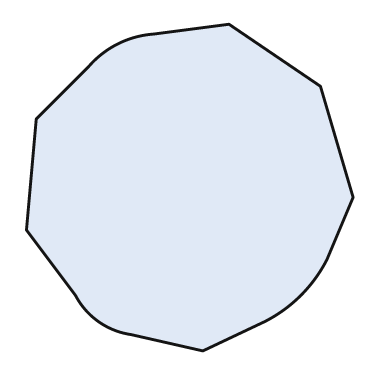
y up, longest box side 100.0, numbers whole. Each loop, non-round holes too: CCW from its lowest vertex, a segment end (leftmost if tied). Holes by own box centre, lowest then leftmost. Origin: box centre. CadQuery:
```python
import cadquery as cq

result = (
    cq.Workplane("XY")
    .moveTo(4.0, -50.0)
    .lineTo(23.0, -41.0)
    .threePointArc((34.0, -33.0), (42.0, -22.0))
    .lineTo(50.0, -3.0)
    .lineTo(40.0, 31.0)
    .lineTo(12.0, 50.0)
    .lineTo(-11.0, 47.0)
    .threePointArc((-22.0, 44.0), (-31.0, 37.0))
    .lineTo(-47.0, 21.0)
    .lineTo(-50.0, -13.0)
    .lineTo(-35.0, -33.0)
    .threePointArc((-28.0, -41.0), (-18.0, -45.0))
    .close()
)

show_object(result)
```